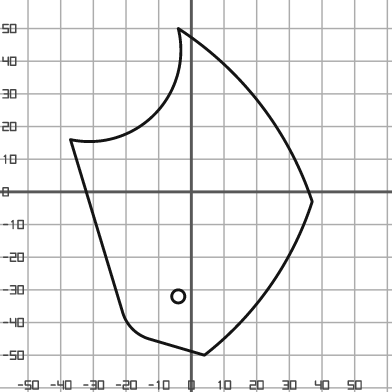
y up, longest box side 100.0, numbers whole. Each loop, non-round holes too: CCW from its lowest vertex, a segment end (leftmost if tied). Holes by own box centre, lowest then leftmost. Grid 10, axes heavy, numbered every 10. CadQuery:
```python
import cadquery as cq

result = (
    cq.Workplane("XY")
    .moveTo(4.0, -50.0)
    .threePointArc((24.0, -29.0), (37.0, -3.0))
    .threePointArc((21.0, 27.0), (-4.0, 50.0))
    .threePointArc((-11.0, 24.0), (-37.0, 16.0))
    .lineTo(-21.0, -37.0)
    .threePointArc((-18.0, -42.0), (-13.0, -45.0))
    .close()
    .moveTo(-4.0, -32.0)
    .circle(2.0)
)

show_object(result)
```